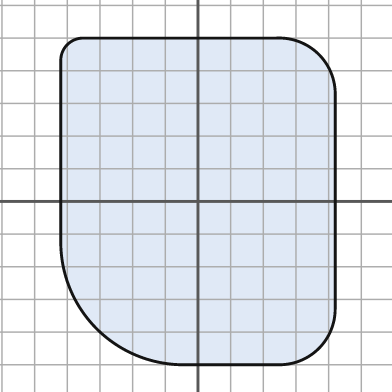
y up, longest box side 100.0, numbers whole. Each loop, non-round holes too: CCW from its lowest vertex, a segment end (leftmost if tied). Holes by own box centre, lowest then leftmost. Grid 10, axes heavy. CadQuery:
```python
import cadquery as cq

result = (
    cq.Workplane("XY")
    .moveTo(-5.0, -50.0)
    .lineTo(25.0, -50.0)
    .threePointArc((37.0, -45.0), (42.0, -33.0))
    .lineTo(42.0, 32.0)
    .threePointArc((37.0, 45.0), (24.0, 50.0))
    .lineTo(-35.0, 50.0)
    .threePointArc((-40.0, 48.0), (-42.0, 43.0))
    .lineTo(-42.0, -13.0)
    .threePointArc((-31.0, -39.0), (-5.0, -50.0))
    .close()
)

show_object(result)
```